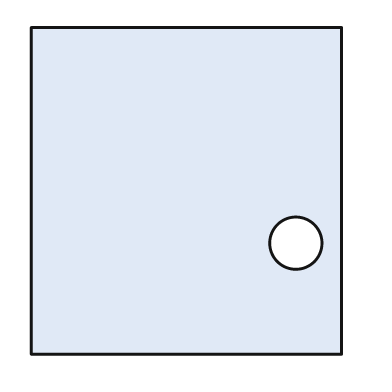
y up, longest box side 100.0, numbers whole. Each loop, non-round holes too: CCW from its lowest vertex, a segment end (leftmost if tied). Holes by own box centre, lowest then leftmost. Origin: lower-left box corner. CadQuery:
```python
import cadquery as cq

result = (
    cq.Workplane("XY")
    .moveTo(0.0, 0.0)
    .lineTo(95.0, 0.0)
    .lineTo(95.0, 100.0)
    .lineTo(0.0, 100.0)
    .close()
    .moveTo(81.0, 34.0)
    .circle(8.0)
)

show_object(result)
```